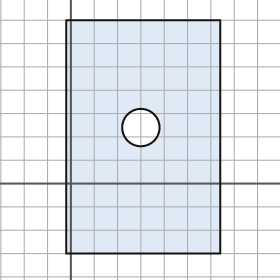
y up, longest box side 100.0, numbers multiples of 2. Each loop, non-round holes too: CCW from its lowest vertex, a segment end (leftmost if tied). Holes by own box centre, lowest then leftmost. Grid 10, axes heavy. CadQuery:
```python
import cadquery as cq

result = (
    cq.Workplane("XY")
    .moveTo(-2.0, -30.0)
    .lineTo(64.0, -30.0)
    .lineTo(64.0, 70.0)
    .lineTo(-2.0, 70.0)
    .close()
    .moveTo(30.0, 24.0)
    .circle(8.0)
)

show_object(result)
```